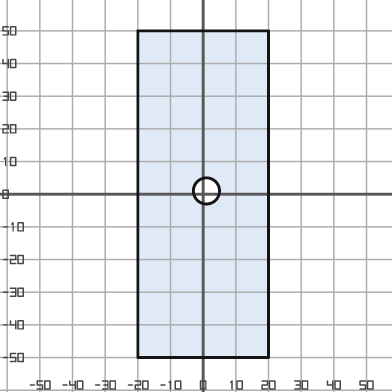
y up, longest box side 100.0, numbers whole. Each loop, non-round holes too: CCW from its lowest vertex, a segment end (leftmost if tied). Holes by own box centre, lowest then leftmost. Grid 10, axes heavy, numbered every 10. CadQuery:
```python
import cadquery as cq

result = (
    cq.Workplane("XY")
    .moveTo(-20.0, -50.0)
    .lineTo(20.0, -50.0)
    .lineTo(20.0, 50.0)
    .lineTo(-20.0, 50.0)
    .close()
    .moveTo(1.0, 1.0)
    .circle(4.0)
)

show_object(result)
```